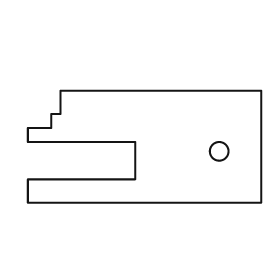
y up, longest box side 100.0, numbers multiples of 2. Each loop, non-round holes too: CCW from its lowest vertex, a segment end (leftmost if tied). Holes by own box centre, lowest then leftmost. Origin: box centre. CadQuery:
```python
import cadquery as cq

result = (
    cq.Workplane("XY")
    .moveTo(-50.0, -24.0)
    .lineTo(50.0, -24.0)
    .lineTo(50.0, 24.0)
    .lineTo(-36.0, 24.0)
    .lineTo(-36.0, 14.0)
    .lineTo(-40.0, 14.0)
    .lineTo(-40.0, 8.0)
    .lineTo(-50.0, 8.0)
    .lineTo(-50.0, 2.0)
    .lineTo(-4.0, 2.0)
    .lineTo(-4.0, -14.0)
    .lineTo(-50.0, -14.0)
    .close()
    .moveTo(32.0, -2.0)
    .circle(4.0)
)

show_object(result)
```